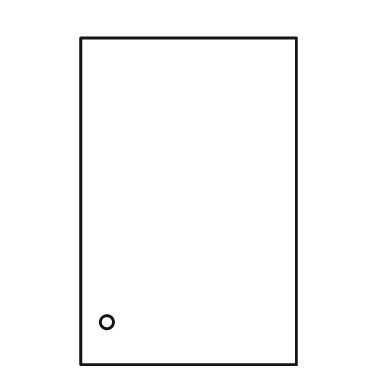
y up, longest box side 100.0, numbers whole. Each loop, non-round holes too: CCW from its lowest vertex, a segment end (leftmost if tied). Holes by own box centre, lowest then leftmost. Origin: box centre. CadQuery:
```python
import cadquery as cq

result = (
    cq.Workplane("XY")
    .moveTo(-33.0, -50.0)
    .lineTo(33.0, -50.0)
    .lineTo(33.0, 50.0)
    .lineTo(-33.0, 50.0)
    .close()
    .moveTo(-25.0, -37.0)
    .circle(2.0)
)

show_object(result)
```